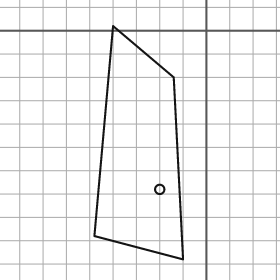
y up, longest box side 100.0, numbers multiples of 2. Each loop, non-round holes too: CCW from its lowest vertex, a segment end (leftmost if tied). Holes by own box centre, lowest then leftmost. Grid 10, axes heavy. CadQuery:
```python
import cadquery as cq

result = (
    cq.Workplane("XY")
    .moveTo(-10.0, -98.0)
    .lineTo(-14.0, -20.0)
    .lineTo(-40.0, 2.0)
    .lineTo(-48.0, -88.0)
    .close()
    .moveTo(-20.0, -68.0)
    .circle(2.0)
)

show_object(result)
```